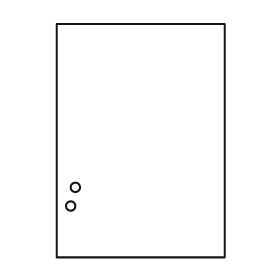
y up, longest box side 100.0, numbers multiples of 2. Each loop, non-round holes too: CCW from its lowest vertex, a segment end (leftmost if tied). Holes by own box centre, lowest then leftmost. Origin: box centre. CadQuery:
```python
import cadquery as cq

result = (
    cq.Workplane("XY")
    .moveTo(-36.0, -50.0)
    .lineTo(36.0, -50.0)
    .lineTo(36.0, 50.0)
    .lineTo(-36.0, 50.0)
    .close()
    .moveTo(-30.0, -28.0)
    .circle(2.0)
    .moveTo(-28.0, -20.0)
    .circle(2.0)
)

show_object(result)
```